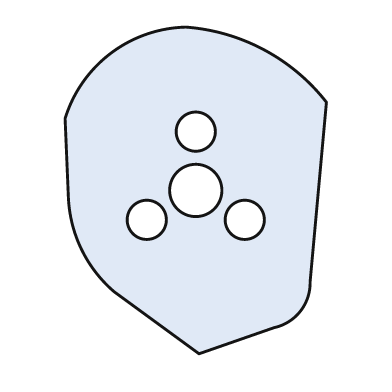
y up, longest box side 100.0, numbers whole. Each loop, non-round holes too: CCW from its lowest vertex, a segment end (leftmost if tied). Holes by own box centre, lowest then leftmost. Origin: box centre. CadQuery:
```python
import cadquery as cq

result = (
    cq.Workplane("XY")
    .moveTo(1.0, -50.0)
    .lineTo(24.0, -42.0)
    .threePointArc((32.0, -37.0), (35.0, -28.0))
    .lineTo(40.0, 27.0)
    .threePointArc((21.0, 43.0), (-3.0, 50.0))
    .threePointArc((-26.0, 42.0), (-40.0, 22.0))
    .lineTo(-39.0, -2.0)
    .threePointArc((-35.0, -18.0), (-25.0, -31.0))
    .close()
    .moveTo(-15.0, -9.0)
    .circle(6.0)
    .moveTo(15.0, -9.0)
    .circle(6.0)
    .moveTo(0.0, 0.0)
    .circle(8.0)
    .moveTo(0.0, 18.0)
    .circle(6.0)
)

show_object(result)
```